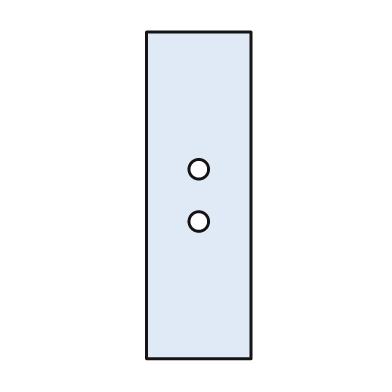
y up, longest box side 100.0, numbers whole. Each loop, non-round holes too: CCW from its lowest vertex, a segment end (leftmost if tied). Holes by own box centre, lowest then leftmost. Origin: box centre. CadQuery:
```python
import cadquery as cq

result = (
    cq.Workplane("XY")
    .moveTo(-16.0, -50.0)
    .lineTo(16.0, -50.0)
    .lineTo(16.0, 50.0)
    .lineTo(-16.0, 50.0)
    .close()
    .moveTo(0.0, -8.0)
    .circle(3.0)
    .moveTo(0.0, 8.0)
    .circle(3.0)
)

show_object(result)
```